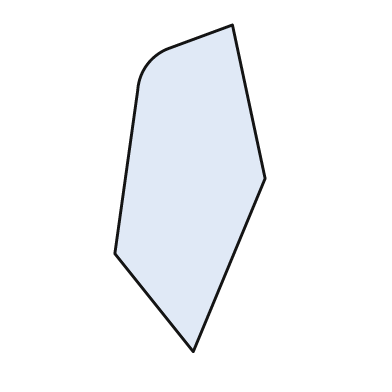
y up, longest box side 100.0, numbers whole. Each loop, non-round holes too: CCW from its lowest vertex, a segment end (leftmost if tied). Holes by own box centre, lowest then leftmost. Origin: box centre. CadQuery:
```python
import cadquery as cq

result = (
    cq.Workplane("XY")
    .moveTo(1.0, -50.0)
    .lineTo(23.0, 3.0)
    .lineTo(13.0, 50.0)
    .lineTo(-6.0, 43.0)
    .threePointArc((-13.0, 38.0), (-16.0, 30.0))
    .lineTo(-23.0, -20.0)
    .close()
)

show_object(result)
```